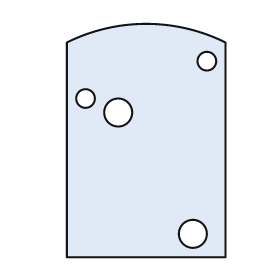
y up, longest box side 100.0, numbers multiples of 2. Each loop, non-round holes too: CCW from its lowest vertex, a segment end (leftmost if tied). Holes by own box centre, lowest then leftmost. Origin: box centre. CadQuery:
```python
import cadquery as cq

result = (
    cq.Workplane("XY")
    .moveTo(-34.0, -50.0)
    .lineTo(34.0, -50.0)
    .lineTo(34.0, 42.0)
    .threePointArc((0.0, 50.0), (-34.0, 42.0))
    .close()
    .moveTo(20.0, -40.0)
    .circle(6.0)
    .moveTo(-12.0, 12.0)
    .circle(6.0)
    .moveTo(-26.0, 18.0)
    .circle(4.0)
    .moveTo(26.0, 34.0)
    .circle(4.0)
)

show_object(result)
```